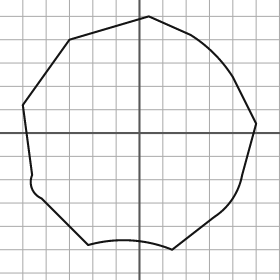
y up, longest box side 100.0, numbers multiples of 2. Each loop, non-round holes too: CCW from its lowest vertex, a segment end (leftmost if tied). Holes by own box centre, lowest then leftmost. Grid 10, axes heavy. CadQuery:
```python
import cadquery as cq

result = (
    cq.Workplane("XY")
    .moveTo(14.0, -50.0)
    .lineTo(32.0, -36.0)
    .threePointArc((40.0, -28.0), (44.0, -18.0))
    .lineTo(50.0, 4.0)
    .lineTo(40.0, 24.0)
    .threePointArc((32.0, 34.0), (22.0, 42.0))
    .lineTo(4.0, 50.0)
    .lineTo(-30.0, 40.0)
    .lineTo(-50.0, 12.0)
    .lineTo(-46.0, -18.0)
    .threePointArc((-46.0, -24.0), (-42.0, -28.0))
    .lineTo(-22.0, -48.0)
    .threePointArc((-4.0, -46.0), (14.0, -50.0))
    .close()
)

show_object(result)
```